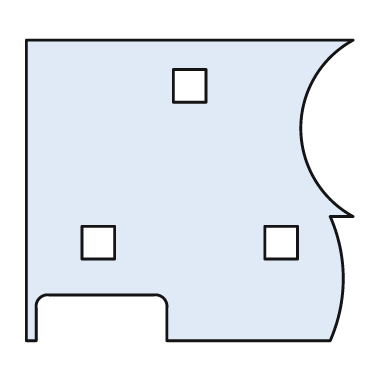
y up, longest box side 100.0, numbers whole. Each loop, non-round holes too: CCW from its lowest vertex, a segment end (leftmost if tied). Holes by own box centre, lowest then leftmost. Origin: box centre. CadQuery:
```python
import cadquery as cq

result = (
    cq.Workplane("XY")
    .moveTo(-50.0, -46.0)
    .lineTo(-47.0, -46.0)
    .lineTo(-47.0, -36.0)
    .threePointArc((-46.0, -33.0), (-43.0, -32.0))
    .lineTo(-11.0, -32.0)
    .threePointArc((-8.0, -33.0), (-7.0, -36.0))
    .lineTo(-7.0, -46.0)
    .lineTo(43.0, -46.0)
    .threePointArc((47.0, -27.0), (43.0, -8.0))
    .lineTo(50.0, -8.0)
    .threePointArc((34.0, 19.0), (50.0, 46.0))
    .lineTo(-50.0, 46.0)
    .close()
    .moveTo(-33.0, -21.0)
    .lineTo(-23.0, -21.0)
    .lineTo(-23.0, -11.0)
    .lineTo(-33.0, -11.0)
    .close()
    .moveTo(23.0, -21.0)
    .lineTo(33.0, -21.0)
    .lineTo(33.0, -11.0)
    .lineTo(23.0, -11.0)
    .close()
    .moveTo(-5.0, 27.0)
    .lineTo(5.0, 27.0)
    .lineTo(5.0, 37.0)
    .lineTo(-5.0, 37.0)
    .close()
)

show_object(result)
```